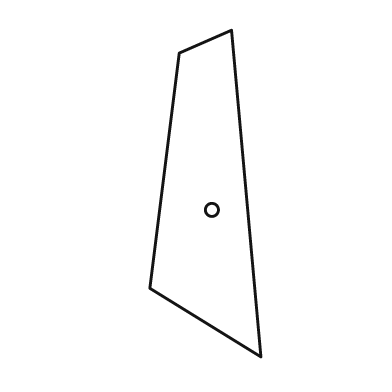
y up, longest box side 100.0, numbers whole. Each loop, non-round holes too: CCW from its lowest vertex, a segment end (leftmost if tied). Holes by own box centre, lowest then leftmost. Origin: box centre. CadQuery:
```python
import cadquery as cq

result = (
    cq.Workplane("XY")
    .moveTo(17.0, -50.0)
    .lineTo(8.0, 50.0)
    .lineTo(-8.0, 43.0)
    .lineTo(-17.0, -29.0)
    .close()
    .moveTo(2.0, -5.0)
    .circle(2.0)
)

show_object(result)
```